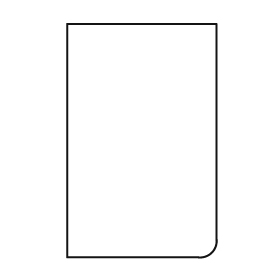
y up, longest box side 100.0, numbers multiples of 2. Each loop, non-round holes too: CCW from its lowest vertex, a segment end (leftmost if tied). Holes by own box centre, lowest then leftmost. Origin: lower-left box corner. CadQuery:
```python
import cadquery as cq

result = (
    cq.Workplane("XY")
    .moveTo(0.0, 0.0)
    .lineTo(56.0, 0.0)
    .threePointArc((62.0, 2.0), (64.0, 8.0))
    .lineTo(64.0, 100.0)
    .lineTo(0.0, 100.0)
    .close()
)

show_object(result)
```